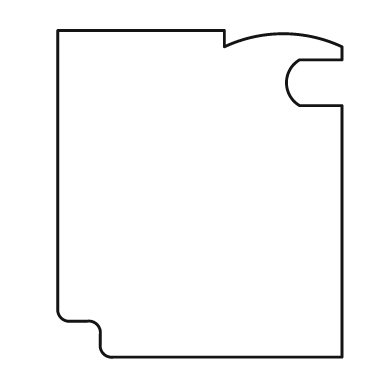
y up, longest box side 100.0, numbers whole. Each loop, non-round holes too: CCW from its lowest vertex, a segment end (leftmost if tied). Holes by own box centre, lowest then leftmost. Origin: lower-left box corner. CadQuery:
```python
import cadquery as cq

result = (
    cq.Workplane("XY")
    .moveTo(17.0, 0.0)
    .lineTo(87.0, 0.0)
    .lineTo(87.0, 77.0)
    .lineTo(74.0, 77.0)
    .threePointArc((70.0, 84.0), (74.0, 91.0))
    .lineTo(87.0, 91.0)
    .lineTo(87.0, 95.0)
    .threePointArc((69.0, 99.0), (51.0, 95.0))
    .lineTo(51.0, 100.0)
    .lineTo(0.0, 100.0)
    .lineTo(0.0, 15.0)
    .threePointArc((1.0, 12.0), (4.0, 11.0))
    .lineTo(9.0, 11.0)
    .threePointArc((12.0, 10.0), (13.0, 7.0))
    .lineTo(13.0, 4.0)
    .threePointArc((14.0, 1.0), (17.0, 0.0))
    .close()
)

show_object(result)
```